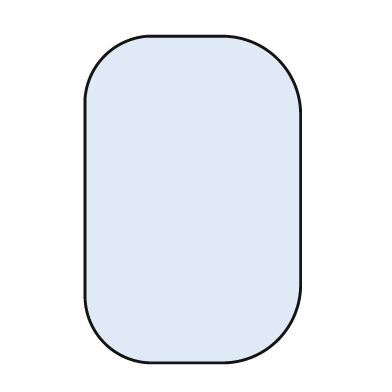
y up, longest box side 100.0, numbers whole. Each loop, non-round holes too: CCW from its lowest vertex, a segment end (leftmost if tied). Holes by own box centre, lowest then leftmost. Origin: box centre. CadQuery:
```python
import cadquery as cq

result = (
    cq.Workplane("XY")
    .moveTo(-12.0, -50.0)
    .lineTo(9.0, -50.0)
    .threePointArc((26.0, -43.0), (33.0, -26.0))
    .lineTo(33.0, 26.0)
    .threePointArc((26.0, 43.0), (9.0, 50.0))
    .lineTo(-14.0, 50.0)
    .threePointArc((-27.0, 44.0), (-33.0, 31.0))
    .lineTo(-33.0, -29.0)
    .threePointArc((-27.0, -44.0), (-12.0, -50.0))
    .close()
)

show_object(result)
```